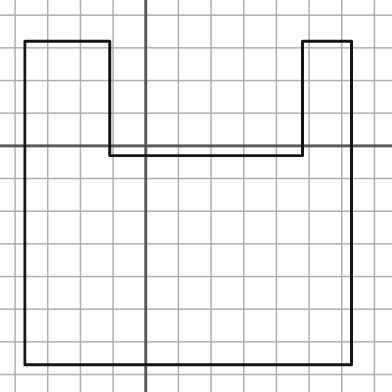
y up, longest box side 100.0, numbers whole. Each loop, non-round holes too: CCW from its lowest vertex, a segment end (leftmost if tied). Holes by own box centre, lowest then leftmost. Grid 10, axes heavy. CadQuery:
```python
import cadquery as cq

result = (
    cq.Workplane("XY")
    .moveTo(-37.0, -67.0)
    .lineTo(63.0, -67.0)
    .lineTo(63.0, 32.0)
    .lineTo(48.0, 32.0)
    .lineTo(48.0, -3.0)
    .lineTo(-11.0, -3.0)
    .lineTo(-11.0, 32.0)
    .lineTo(-37.0, 32.0)
    .close()
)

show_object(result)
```